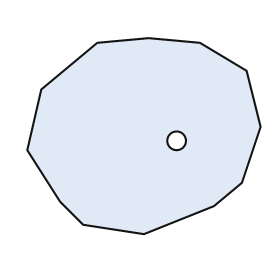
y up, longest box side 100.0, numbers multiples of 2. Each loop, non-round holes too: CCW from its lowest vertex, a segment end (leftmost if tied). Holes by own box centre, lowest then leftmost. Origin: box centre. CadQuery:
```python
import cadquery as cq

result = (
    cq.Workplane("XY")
    .moveTo(0.0, -42.0)
    .lineTo(30.0, -30.0)
    .lineTo(42.0, -20.0)
    .lineTo(50.0, 4.0)
    .lineTo(44.0, 28.0)
    .lineTo(24.0, 40.0)
    .lineTo(2.0, 42.0)
    .lineTo(-20.0, 40.0)
    .lineTo(-44.0, 20.0)
    .lineTo(-50.0, -6.0)
    .lineTo(-36.0, -28.0)
    .lineTo(-26.0, -38.0)
    .close()
    .moveTo(14.0, -2.0)
    .circle(4.0)
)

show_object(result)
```